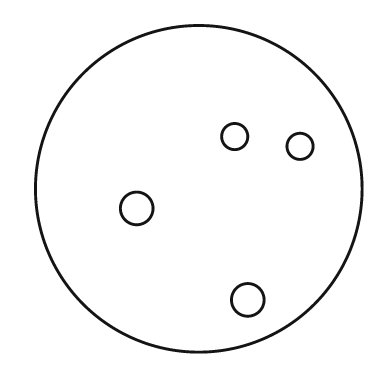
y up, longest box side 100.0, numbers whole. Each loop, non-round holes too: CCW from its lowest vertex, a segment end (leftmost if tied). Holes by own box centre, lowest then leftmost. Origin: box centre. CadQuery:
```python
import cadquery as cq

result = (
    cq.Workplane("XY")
    .moveTo(0.0, 0.0)
    .circle(50.0)
    .moveTo(15.0, -34.0)
    .circle(5.0)
    .moveTo(-19.0, -6.0)
    .circle(5.0)
    .moveTo(31.0, 13.0)
    .circle(4.0)
    .moveTo(11.0, 16.0)
    .circle(4.0)
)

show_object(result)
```